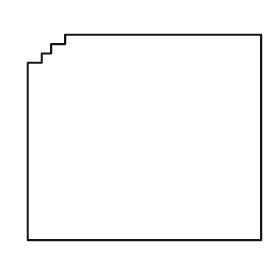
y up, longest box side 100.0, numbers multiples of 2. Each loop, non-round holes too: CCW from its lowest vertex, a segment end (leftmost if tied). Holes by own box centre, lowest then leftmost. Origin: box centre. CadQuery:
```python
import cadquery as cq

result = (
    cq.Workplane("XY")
    .moveTo(-50.0, -44.0)
    .lineTo(50.0, -44.0)
    .lineTo(50.0, 44.0)
    .lineTo(-34.0, 44.0)
    .lineTo(-34.0, 40.0)
    .lineTo(-40.0, 40.0)
    .lineTo(-40.0, 36.0)
    .lineTo(-44.0, 36.0)
    .lineTo(-44.0, 32.0)
    .lineTo(-50.0, 32.0)
    .close()
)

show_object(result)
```